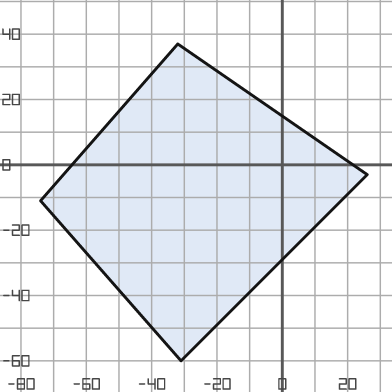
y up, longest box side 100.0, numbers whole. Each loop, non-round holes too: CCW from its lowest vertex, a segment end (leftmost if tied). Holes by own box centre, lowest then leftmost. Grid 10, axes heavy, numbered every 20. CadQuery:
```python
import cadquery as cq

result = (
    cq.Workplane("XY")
    .moveTo(-31.0, -60.0)
    .lineTo(26.0, -3.0)
    .lineTo(-32.0, 37.0)
    .lineTo(-74.0, -11.0)
    .close()
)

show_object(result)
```